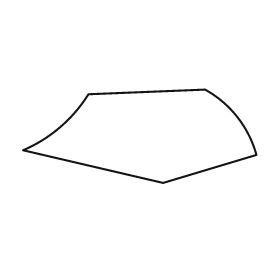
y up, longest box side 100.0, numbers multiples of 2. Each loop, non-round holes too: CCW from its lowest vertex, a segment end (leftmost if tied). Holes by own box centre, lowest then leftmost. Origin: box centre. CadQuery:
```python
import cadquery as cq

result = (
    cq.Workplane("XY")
    .moveTo(10.0, -20.0)
    .lineTo(50.0, -8.0)
    .threePointArc((42.0, 8.0), (28.0, 20.0))
    .lineTo(-22.0, 18.0)
    .threePointArc((-34.0, 4.0), (-50.0, -6.0))
    .close()
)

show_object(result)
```